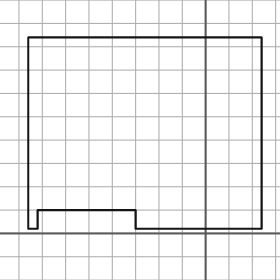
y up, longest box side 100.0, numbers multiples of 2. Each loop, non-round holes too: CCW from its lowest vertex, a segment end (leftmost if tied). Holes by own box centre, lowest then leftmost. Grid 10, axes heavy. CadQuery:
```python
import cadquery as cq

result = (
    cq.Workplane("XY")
    .moveTo(-76.0, 2.0)
    .lineTo(-72.0, 2.0)
    .lineTo(-72.0, 10.0)
    .lineTo(-30.0, 10.0)
    .lineTo(-30.0, 2.0)
    .lineTo(24.0, 2.0)
    .lineTo(24.0, 84.0)
    .lineTo(-76.0, 84.0)
    .close()
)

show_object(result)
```